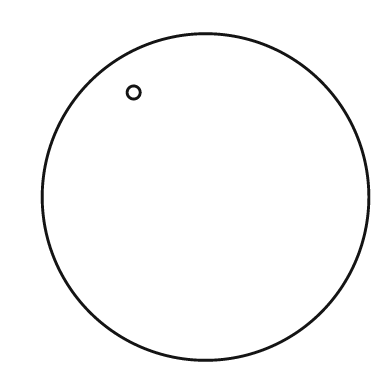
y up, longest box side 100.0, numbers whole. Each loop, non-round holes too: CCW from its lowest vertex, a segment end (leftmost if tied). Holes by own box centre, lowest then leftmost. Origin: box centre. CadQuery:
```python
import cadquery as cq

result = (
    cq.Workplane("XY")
    .moveTo(0.0, 0.0)
    .circle(50.0)
    .moveTo(-22.0, 32.0)
    .circle(2.0)
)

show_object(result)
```